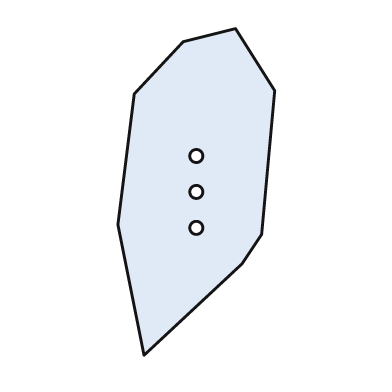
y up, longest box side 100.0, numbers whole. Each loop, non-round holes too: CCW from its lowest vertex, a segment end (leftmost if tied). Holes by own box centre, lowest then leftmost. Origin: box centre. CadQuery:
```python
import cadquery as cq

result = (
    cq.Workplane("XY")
    .moveTo(-16.0, -50.0)
    .lineTo(14.0, -22.0)
    .lineTo(20.0, -13.0)
    .lineTo(24.0, 31.0)
    .lineTo(12.0, 50.0)
    .lineTo(-4.0, 46.0)
    .lineTo(-19.0, 30.0)
    .lineTo(-24.0, -10.0)
    .close()
    .moveTo(0.0, -11.0)
    .circle(2.0)
    .moveTo(0.0, 0.0)
    .circle(2.0)
    .moveTo(0.0, 11.0)
    .circle(2.0)
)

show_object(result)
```